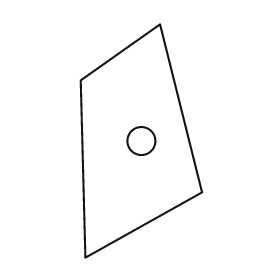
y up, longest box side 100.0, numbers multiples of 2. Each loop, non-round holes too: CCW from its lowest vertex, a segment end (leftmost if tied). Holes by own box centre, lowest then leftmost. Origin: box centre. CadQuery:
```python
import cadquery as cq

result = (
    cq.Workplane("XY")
    .moveTo(-24.0, -50.0)
    .lineTo(26.0, -22.0)
    .lineTo(8.0, 50.0)
    .lineTo(-26.0, 26.0)
    .close()
    .moveTo(0.0, 0.0)
    .circle(6.0)
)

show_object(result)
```